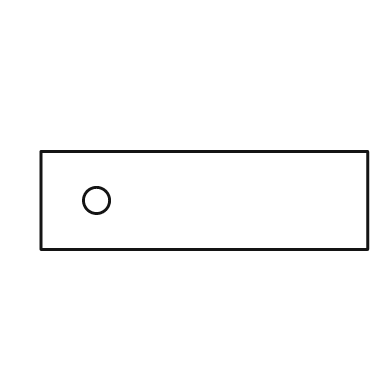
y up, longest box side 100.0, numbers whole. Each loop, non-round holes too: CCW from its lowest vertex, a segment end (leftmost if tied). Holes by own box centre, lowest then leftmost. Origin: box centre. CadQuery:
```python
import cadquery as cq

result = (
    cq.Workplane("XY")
    .moveTo(-50.0, -15.0)
    .lineTo(50.0, -15.0)
    .lineTo(50.0, 15.0)
    .lineTo(-50.0, 15.0)
    .close()
    .moveTo(-33.0, 0.0)
    .circle(4.0)
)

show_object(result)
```